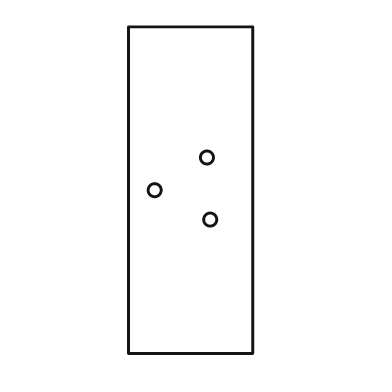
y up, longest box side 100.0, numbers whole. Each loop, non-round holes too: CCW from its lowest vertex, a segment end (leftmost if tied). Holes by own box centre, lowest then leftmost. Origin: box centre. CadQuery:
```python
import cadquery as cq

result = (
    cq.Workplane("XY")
    .moveTo(-19.0, -50.0)
    .lineTo(19.0, -50.0)
    .lineTo(19.0, 50.0)
    .lineTo(-19.0, 50.0)
    .close()
    .moveTo(6.0, -9.0)
    .circle(2.0)
    .moveTo(-11.0, 0.0)
    .circle(2.0)
    .moveTo(5.0, 10.0)
    .circle(2.0)
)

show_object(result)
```